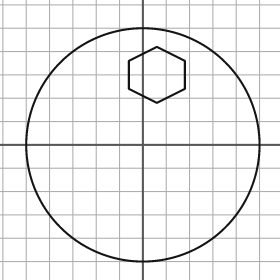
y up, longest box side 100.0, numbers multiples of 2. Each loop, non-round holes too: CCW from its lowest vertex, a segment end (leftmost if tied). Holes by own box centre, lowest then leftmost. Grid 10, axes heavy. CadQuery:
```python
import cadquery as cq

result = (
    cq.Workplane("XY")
    .moveTo(0.0, 0.0)
    .circle(50.0)
    .moveTo(6.0, 18.0)
    .lineTo(18.0, 24.0)
    .lineTo(18.0, 36.0)
    .lineTo(6.0, 42.0)
    .lineTo(-6.0, 36.0)
    .lineTo(-6.0, 24.0)
    .close()
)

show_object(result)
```